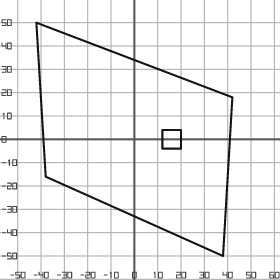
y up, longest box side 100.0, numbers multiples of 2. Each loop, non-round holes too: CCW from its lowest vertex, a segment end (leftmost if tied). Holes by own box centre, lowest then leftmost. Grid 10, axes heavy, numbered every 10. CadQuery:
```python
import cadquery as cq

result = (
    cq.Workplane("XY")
    .moveTo(38.0, -50.0)
    .lineTo(42.0, 18.0)
    .lineTo(-42.0, 50.0)
    .lineTo(-38.0, -16.0)
    .close()
    .moveTo(12.0, -4.0)
    .lineTo(20.0, -4.0)
    .lineTo(20.0, 4.0)
    .lineTo(12.0, 4.0)
    .close()
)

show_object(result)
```